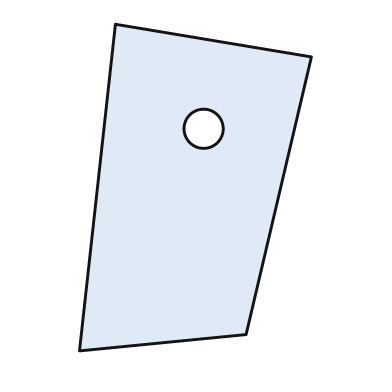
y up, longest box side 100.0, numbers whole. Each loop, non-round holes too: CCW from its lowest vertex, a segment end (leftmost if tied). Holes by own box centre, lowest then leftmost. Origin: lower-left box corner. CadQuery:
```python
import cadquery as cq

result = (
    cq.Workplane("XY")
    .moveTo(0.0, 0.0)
    .lineTo(51.0, 5.0)
    .lineTo(71.0, 90.0)
    .lineTo(11.0, 100.0)
    .close()
    .moveTo(38.0, 68.0)
    .circle(6.0)
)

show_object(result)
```